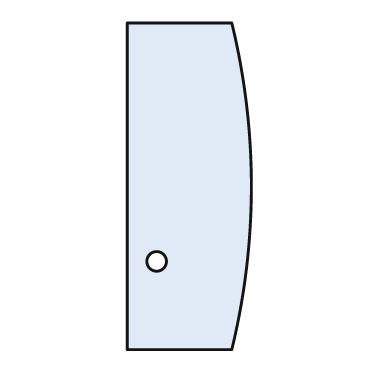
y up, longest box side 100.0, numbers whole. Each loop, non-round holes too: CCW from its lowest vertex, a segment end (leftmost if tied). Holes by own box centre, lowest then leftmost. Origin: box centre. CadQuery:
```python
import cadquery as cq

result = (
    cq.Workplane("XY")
    .moveTo(-19.0, -50.0)
    .lineTo(13.0, -50.0)
    .threePointArc((19.0, 0.0), (13.0, 50.0))
    .lineTo(-19.0, 50.0)
    .close()
    .moveTo(-10.0, -23.0)
    .circle(3.0)
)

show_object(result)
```